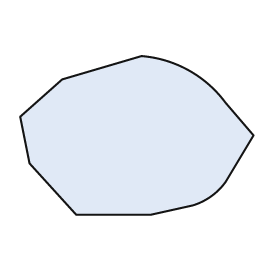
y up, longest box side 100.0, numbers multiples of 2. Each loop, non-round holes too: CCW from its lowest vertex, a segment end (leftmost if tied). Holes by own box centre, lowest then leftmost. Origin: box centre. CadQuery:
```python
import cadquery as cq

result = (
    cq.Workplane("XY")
    .moveTo(-26.0, -34.0)
    .lineTo(6.0, -34.0)
    .lineTo(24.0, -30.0)
    .threePointArc((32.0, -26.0), (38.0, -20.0))
    .lineTo(50.0, 0.0)
    .lineTo(38.0, 14.0)
    .threePointArc((22.0, 28.0), (2.0, 34.0))
    .lineTo(-32.0, 24.0)
    .lineTo(-50.0, 8.0)
    .lineTo(-46.0, -12.0)
    .close()
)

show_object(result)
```